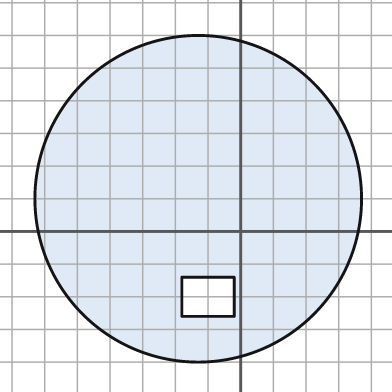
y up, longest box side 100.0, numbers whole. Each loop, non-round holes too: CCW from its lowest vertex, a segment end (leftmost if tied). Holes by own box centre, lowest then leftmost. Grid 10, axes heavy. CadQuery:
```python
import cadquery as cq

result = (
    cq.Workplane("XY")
    .moveTo(-13.0, 10.0)
    .circle(50.0)
    .moveTo(-18.0, -26.0)
    .lineTo(-2.0, -26.0)
    .lineTo(-2.0, -14.0)
    .lineTo(-18.0, -14.0)
    .close()
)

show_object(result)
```